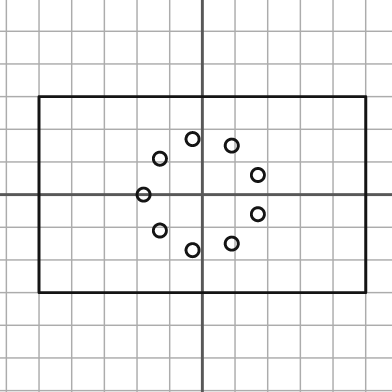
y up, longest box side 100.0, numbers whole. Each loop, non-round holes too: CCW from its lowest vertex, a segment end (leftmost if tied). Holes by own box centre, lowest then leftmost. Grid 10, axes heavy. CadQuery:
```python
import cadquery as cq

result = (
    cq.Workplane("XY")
    .moveTo(-50.0, -30.0)
    .lineTo(50.0, -30.0)
    .lineTo(50.0, 30.0)
    .lineTo(-50.0, 30.0)
    .close()
    .moveTo(-3.0, -17.0)
    .circle(2.0)
    .moveTo(9.0, -15.0)
    .circle(2.0)
    .moveTo(-13.0, -11.0)
    .circle(2.0)
    .moveTo(17.0, -6.0)
    .circle(2.0)
    .moveTo(-18.0, 0.0)
    .circle(2.0)
    .moveTo(17.0, 6.0)
    .circle(2.0)
    .moveTo(-13.0, 11.0)
    .circle(2.0)
    .moveTo(9.0, 15.0)
    .circle(2.0)
    .moveTo(-3.0, 17.0)
    .circle(2.0)
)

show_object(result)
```